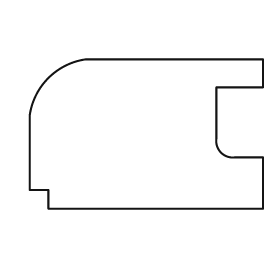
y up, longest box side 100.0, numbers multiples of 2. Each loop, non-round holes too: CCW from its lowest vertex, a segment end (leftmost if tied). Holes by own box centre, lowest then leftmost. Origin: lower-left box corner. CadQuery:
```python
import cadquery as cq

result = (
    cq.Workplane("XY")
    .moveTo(8.0, 0.0)
    .lineTo(100.0, 0.0)
    .lineTo(100.0, 22.0)
    .lineTo(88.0, 22.0)
    .threePointArc((82.0, 24.0), (80.0, 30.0))
    .lineTo(80.0, 52.0)
    .lineTo(100.0, 52.0)
    .lineTo(100.0, 64.0)
    .lineTo(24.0, 64.0)
    .threePointArc((8.0, 56.0), (0.0, 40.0))
    .lineTo(0.0, 8.0)
    .lineTo(8.0, 8.0)
    .close()
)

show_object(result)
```